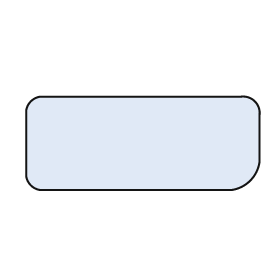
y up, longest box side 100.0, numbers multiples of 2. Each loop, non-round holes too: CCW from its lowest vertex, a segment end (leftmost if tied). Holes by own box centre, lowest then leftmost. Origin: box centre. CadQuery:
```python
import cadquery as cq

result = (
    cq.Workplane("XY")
    .moveTo(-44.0, -20.0)
    .lineTo(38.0, -20.0)
    .threePointArc((46.0, -16.0), (50.0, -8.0))
    .lineTo(50.0, 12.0)
    .threePointArc((48.0, 18.0), (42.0, 20.0))
    .lineTo(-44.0, 20.0)
    .threePointArc((-48.0, 18.0), (-50.0, 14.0))
    .lineTo(-50.0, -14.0)
    .threePointArc((-48.0, -18.0), (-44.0, -20.0))
    .close()
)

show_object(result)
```